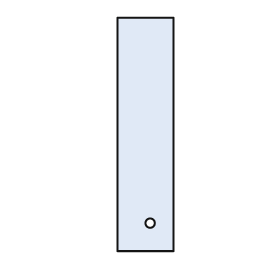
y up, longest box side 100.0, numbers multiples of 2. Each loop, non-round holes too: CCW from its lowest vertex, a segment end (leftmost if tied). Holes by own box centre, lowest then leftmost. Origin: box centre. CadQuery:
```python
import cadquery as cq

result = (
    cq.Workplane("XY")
    .moveTo(-12.0, -50.0)
    .lineTo(12.0, -50.0)
    .lineTo(12.0, 50.0)
    .lineTo(-12.0, 50.0)
    .close()
    .moveTo(2.0, -38.0)
    .circle(2.0)
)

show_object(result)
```